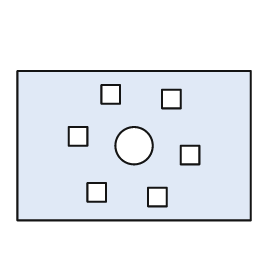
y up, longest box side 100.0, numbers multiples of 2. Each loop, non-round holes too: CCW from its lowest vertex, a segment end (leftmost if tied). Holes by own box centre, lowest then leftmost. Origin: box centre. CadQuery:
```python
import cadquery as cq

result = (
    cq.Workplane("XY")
    .moveTo(-50.0, -32.0)
    .lineTo(50.0, -32.0)
    .lineTo(50.0, 32.0)
    .lineTo(-50.0, 32.0)
    .close()
    .moveTo(6.0, -26.0)
    .lineTo(14.0, -26.0)
    .lineTo(14.0, -18.0)
    .lineTo(6.0, -18.0)
    .close()
    .moveTo(-20.0, -24.0)
    .lineTo(-12.0, -24.0)
    .lineTo(-12.0, -16.0)
    .lineTo(-20.0, -16.0)
    .close()
    .moveTo(20.0, -8.0)
    .lineTo(28.0, -8.0)
    .lineTo(28.0, 0.0)
    .lineTo(20.0, 0.0)
    .close()
    .moveTo(0.0, 0.0)
    .circle(8.0)
    .moveTo(-28.0, 0.0)
    .lineTo(-20.0, 0.0)
    .lineTo(-20.0, 8.0)
    .lineTo(-28.0, 8.0)
    .close()
    .moveTo(12.0, 16.0)
    .lineTo(20.0, 16.0)
    .lineTo(20.0, 24.0)
    .lineTo(12.0, 24.0)
    .close()
    .moveTo(-14.0, 18.0)
    .lineTo(-6.0, 18.0)
    .lineTo(-6.0, 26.0)
    .lineTo(-14.0, 26.0)
    .close()
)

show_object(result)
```